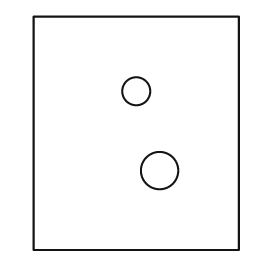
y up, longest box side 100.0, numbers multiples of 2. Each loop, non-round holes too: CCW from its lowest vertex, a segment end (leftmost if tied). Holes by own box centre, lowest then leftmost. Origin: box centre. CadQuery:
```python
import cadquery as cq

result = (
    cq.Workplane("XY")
    .moveTo(-44.0, -50.0)
    .lineTo(44.0, -50.0)
    .lineTo(44.0, 50.0)
    .lineTo(-44.0, 50.0)
    .close()
    .moveTo(10.0, -16.0)
    .circle(8.0)
    .moveTo(0.0, 18.0)
    .circle(6.0)
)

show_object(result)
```